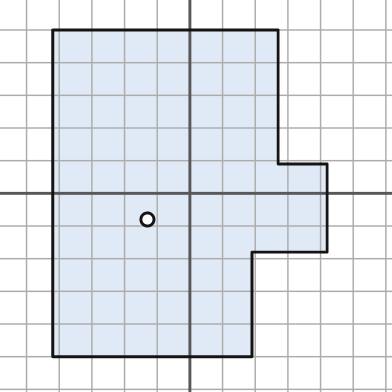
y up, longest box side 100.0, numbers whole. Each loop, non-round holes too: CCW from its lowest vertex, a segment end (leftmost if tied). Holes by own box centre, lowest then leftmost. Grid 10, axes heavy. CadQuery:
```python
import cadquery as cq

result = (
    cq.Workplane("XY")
    .moveTo(-42.0, -50.0)
    .lineTo(19.0, -50.0)
    .lineTo(19.0, -18.0)
    .lineTo(42.0, -18.0)
    .lineTo(42.0, 9.0)
    .lineTo(27.0, 9.0)
    .lineTo(27.0, 50.0)
    .lineTo(-42.0, 50.0)
    .close()
    .moveTo(-13.0, -8.0)
    .circle(2.0)
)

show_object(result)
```